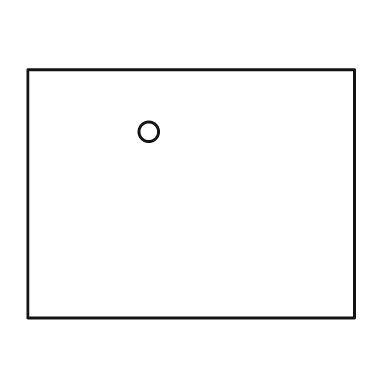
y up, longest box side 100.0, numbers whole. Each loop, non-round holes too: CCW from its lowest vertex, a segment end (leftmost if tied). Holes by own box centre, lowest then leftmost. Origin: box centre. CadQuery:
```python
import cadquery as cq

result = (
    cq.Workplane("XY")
    .moveTo(-50.0, -38.0)
    .lineTo(50.0, -38.0)
    .lineTo(50.0, 38.0)
    .lineTo(-50.0, 38.0)
    .close()
    .moveTo(-13.0, 19.0)
    .circle(3.0)
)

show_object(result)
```